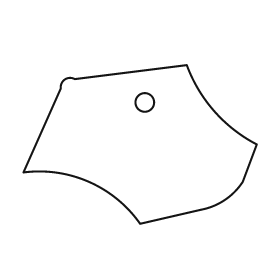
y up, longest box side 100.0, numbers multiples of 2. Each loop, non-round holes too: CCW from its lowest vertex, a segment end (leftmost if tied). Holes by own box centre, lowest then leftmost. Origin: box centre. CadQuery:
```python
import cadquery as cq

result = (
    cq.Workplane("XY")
    .moveTo(0.0, -34.0)
    .lineTo(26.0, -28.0)
    .threePointArc((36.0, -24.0), (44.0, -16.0))
    .lineTo(50.0, 0.0)
    .threePointArc((32.0, 14.0), (20.0, 34.0))
    .lineTo(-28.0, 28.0)
    .threePointArc((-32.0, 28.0), (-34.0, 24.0))
    .lineTo(-50.0, -12.0)
    .threePointArc((-22.0, -16.0), (0.0, -34.0))
    .close()
    .moveTo(2.0, 18.0)
    .circle(4.0)
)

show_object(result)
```